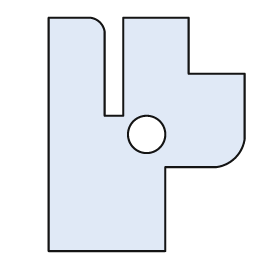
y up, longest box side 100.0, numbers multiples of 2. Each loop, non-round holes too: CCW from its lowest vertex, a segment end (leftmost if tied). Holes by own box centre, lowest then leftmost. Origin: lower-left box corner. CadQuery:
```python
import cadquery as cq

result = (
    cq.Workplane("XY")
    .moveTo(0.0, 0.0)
    .lineTo(50.0, 0.0)
    .lineTo(50.0, 36.0)
    .lineTo(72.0, 36.0)
    .threePointArc((80.0, 40.0), (84.0, 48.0))
    .lineTo(84.0, 76.0)
    .lineTo(60.0, 76.0)
    .lineTo(60.0, 100.0)
    .lineTo(32.0, 100.0)
    .lineTo(32.0, 58.0)
    .lineTo(24.0, 58.0)
    .lineTo(24.0, 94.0)
    .threePointArc((22.0, 98.0), (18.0, 100.0))
    .lineTo(0.0, 100.0)
    .close()
    .moveTo(42.0, 50.0)
    .circle(8.0)
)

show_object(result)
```